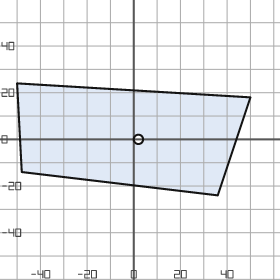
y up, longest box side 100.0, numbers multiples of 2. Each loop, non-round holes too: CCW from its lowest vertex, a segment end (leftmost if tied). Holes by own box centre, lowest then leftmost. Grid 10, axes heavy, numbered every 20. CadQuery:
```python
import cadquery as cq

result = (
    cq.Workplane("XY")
    .moveTo(36.0, -24.0)
    .lineTo(50.0, 18.0)
    .lineTo(-50.0, 24.0)
    .lineTo(-48.0, -14.0)
    .close()
    .moveTo(2.0, 0.0)
    .circle(2.0)
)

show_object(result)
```